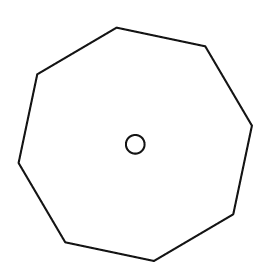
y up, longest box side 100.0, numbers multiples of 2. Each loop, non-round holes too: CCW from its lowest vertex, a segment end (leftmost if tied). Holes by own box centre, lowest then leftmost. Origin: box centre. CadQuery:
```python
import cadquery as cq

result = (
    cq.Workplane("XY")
    .moveTo(8.0, -50.0)
    .lineTo(42.0, -30.0)
    .lineTo(50.0, 8.0)
    .lineTo(30.0, 42.0)
    .lineTo(-8.0, 50.0)
    .lineTo(-42.0, 30.0)
    .lineTo(-50.0, -8.0)
    .lineTo(-30.0, -42.0)
    .close()
    .moveTo(0.0, 0.0)
    .circle(4.0)
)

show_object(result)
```